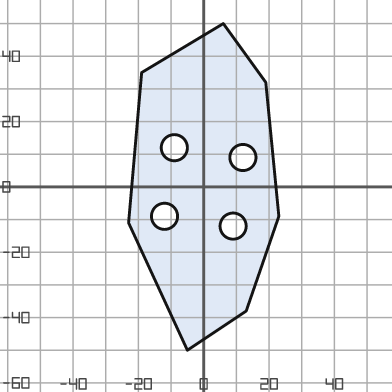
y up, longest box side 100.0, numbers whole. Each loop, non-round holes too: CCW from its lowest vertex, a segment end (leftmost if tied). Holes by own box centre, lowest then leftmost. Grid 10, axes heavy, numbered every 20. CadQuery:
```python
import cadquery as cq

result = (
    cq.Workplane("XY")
    .moveTo(-5.0, -50.0)
    .lineTo(13.0, -38.0)
    .lineTo(23.0, -9.0)
    .lineTo(19.0, 32.0)
    .lineTo(6.0, 50.0)
    .lineTo(-19.0, 35.0)
    .lineTo(-23.0, -11.0)
    .close()
    .moveTo(9.0, -12.0)
    .circle(4.0)
    .moveTo(-12.0, -9.0)
    .circle(4.0)
    .moveTo(12.0, 9.0)
    .circle(4.0)
    .moveTo(-9.0, 12.0)
    .circle(4.0)
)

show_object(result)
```